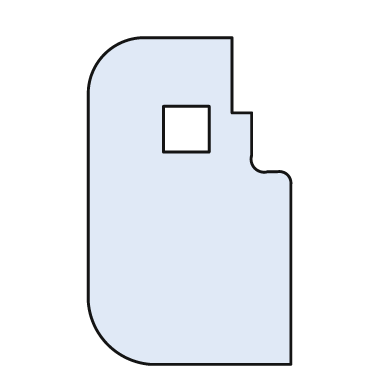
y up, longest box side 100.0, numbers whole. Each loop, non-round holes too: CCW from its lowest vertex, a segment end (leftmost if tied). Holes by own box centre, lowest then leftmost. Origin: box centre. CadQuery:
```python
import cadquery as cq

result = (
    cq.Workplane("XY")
    .moveTo(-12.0, -50.0)
    .lineTo(31.0, -50.0)
    .lineTo(31.0, 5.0)
    .threePointArc((30.0, 8.0), (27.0, 9.0))
    .lineTo(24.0, 9.0)
    .threePointArc((20.0, 10.0), (19.0, 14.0))
    .lineTo(19.0, 27.0)
    .lineTo(13.0, 27.0)
    .lineTo(13.0, 50.0)
    .lineTo(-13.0, 50.0)
    .threePointArc((-26.0, 45.0), (-31.0, 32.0))
    .lineTo(-31.0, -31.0)
    .threePointArc((-25.0, -44.0), (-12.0, -50.0))
    .close()
    .moveTo(-8.0, 15.0)
    .lineTo(6.0, 15.0)
    .lineTo(6.0, 29.0)
    .lineTo(-8.0, 29.0)
    .close()
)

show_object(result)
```